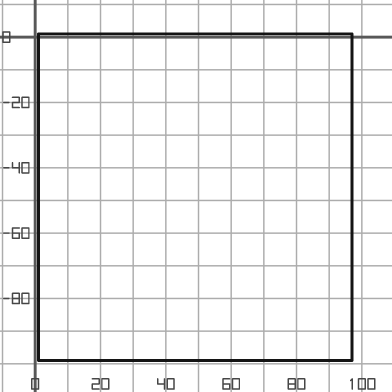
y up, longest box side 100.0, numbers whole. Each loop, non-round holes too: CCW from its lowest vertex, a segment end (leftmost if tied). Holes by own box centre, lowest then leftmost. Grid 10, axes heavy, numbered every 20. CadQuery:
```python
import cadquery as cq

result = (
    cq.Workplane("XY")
    .moveTo(1.0, -99.0)
    .lineTo(97.0, -99.0)
    .lineTo(97.0, 1.0)
    .lineTo(1.0, 1.0)
    .close()
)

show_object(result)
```